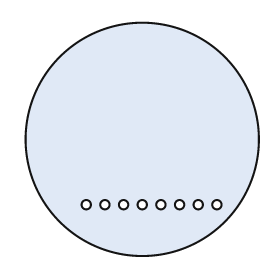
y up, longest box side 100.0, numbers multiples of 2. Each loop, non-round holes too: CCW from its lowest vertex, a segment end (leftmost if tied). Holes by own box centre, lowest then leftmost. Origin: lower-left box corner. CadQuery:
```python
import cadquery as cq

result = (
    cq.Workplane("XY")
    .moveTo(50.0, 50.0)
    .circle(50.0)
    .moveTo(26.0, 22.0)
    .circle(2.0)
    .moveTo(34.0, 22.0)
    .circle(2.0)
    .moveTo(42.0, 22.0)
    .circle(2.0)
    .moveTo(50.0, 22.0)
    .circle(2.0)
    .moveTo(58.0, 22.0)
    .circle(2.0)
    .moveTo(66.0, 22.0)
    .circle(2.0)
    .moveTo(74.0, 22.0)
    .circle(2.0)
    .moveTo(82.0, 22.0)
    .circle(2.0)
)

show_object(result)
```